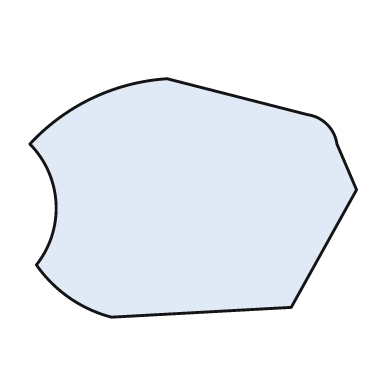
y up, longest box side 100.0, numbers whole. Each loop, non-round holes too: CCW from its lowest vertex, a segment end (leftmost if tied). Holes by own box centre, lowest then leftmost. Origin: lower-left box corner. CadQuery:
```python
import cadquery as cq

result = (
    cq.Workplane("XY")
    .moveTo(25.0, 0.0)
    .lineTo(80.0, 3.0)
    .lineTo(100.0, 39.0)
    .lineTo(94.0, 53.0)
    .threePointArc((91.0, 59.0), (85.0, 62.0))
    .lineTo(42.0, 73.0)
    .threePointArc((19.0, 67.0), (0.0, 53.0))
    .threePointArc((8.0, 35.0), (2.0, 16.0))
    .threePointArc((12.0, 6.0), (25.0, 0.0))
    .close()
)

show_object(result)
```